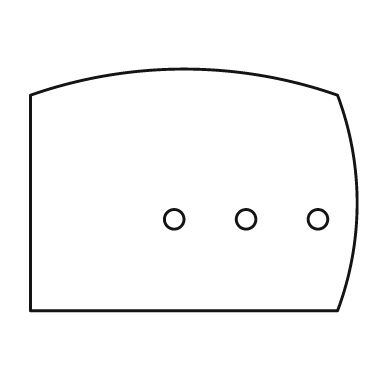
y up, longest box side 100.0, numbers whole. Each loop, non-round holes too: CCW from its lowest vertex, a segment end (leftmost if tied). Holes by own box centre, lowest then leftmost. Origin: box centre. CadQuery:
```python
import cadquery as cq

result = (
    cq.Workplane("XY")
    .moveTo(-50.0, -37.0)
    .lineTo(44.0, -37.0)
    .threePointArc((50.0, -4.0), (44.0, 29.0))
    .threePointArc((-3.0, 37.0), (-50.0, 29.0))
    .close()
    .moveTo(-6.0, -9.0)
    .circle(3.0)
    .moveTo(16.0, -9.0)
    .circle(3.0)
    .moveTo(38.0, -9.0)
    .circle(3.0)
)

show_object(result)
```